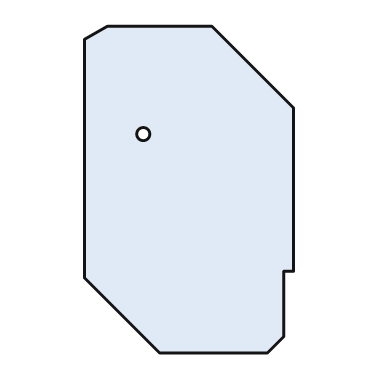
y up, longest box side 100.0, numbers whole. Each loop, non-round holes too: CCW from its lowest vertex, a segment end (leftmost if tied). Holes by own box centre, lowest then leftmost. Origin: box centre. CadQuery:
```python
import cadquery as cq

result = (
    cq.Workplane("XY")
    .moveTo(-9.0, -50.0)
    .lineTo(24.0, -50.0)
    .lineTo(29.0, -45.0)
    .lineTo(29.0, -25.0)
    .lineTo(32.0, -25.0)
    .lineTo(32.0, 25.0)
    .lineTo(7.0, 50.0)
    .lineTo(-25.0, 50.0)
    .lineTo(-32.0, 46.0)
    .lineTo(-32.0, -27.0)
    .close()
    .moveTo(-14.0, 17.0)
    .circle(2.0)
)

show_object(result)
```